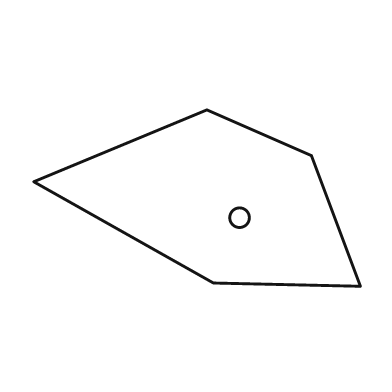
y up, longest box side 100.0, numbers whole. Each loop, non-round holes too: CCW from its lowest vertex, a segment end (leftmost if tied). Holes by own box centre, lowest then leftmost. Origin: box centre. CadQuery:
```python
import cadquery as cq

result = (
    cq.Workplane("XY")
    .moveTo(50.0, -27.0)
    .lineTo(35.0, 13.0)
    .lineTo(3.0, 27.0)
    .lineTo(-50.0, 5.0)
    .lineTo(5.0, -26.0)
    .close()
    .moveTo(13.0, -6.0)
    .circle(3.0)
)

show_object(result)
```